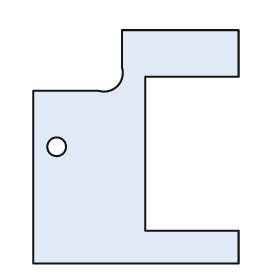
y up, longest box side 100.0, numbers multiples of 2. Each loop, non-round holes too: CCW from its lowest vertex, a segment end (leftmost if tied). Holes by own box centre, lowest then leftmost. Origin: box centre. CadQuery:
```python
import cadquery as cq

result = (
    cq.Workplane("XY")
    .moveTo(-44.0, -50.0)
    .lineTo(44.0, -50.0)
    .lineTo(44.0, -36.0)
    .lineTo(4.0, -36.0)
    .lineTo(4.0, 30.0)
    .lineTo(44.0, 30.0)
    .lineTo(44.0, 50.0)
    .lineTo(-6.0, 50.0)
    .lineTo(-6.0, 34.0)
    .threePointArc((-8.0, 26.0), (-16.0, 24.0))
    .lineTo(-44.0, 24.0)
    .close()
    .moveTo(-34.0, 0.0)
    .circle(4.0)
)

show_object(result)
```